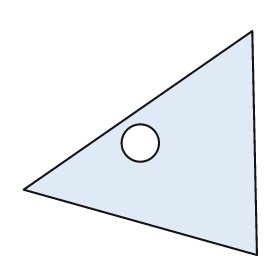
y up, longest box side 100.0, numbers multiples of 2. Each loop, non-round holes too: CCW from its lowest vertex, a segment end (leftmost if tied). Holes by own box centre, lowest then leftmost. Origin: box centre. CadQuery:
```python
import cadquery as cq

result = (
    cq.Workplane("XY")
    .moveTo(50.0, -48.0)
    .lineTo(48.0, 48.0)
    .lineTo(-50.0, -20.0)
    .close()
    .moveTo(0.0, 0.0)
    .circle(8.0)
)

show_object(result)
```